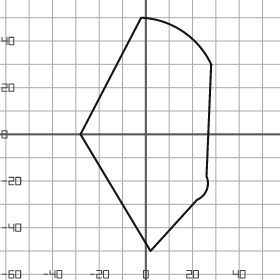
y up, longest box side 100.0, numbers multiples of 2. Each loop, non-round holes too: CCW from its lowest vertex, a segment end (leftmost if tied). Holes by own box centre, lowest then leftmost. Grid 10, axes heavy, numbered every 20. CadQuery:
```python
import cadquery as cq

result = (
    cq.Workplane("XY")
    .moveTo(2.0, -50.0)
    .lineTo(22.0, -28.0)
    .threePointArc((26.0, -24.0), (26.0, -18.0))
    .lineTo(28.0, 30.0)
    .threePointArc((16.0, 44.0), (-2.0, 50.0))
    .lineTo(-28.0, 0.0)
    .close()
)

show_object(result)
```